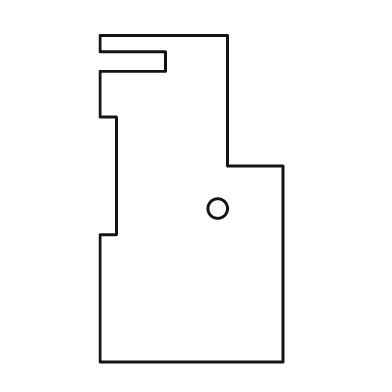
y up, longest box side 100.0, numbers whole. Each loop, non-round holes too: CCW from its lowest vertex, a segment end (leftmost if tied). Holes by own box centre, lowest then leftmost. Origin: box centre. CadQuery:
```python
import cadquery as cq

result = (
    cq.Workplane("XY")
    .moveTo(-28.0, -50.0)
    .lineTo(28.0, -50.0)
    .lineTo(28.0, 10.0)
    .lineTo(11.0, 10.0)
    .lineTo(11.0, 50.0)
    .lineTo(-28.0, 50.0)
    .lineTo(-28.0, 45.0)
    .lineTo(-8.0, 45.0)
    .lineTo(-8.0, 39.0)
    .lineTo(-28.0, 39.0)
    .lineTo(-28.0, 25.0)
    .lineTo(-23.0, 25.0)
    .lineTo(-23.0, -11.0)
    .lineTo(-28.0, -11.0)
    .close()
    .moveTo(8.0, -3.0)
    .circle(3.0)
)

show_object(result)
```